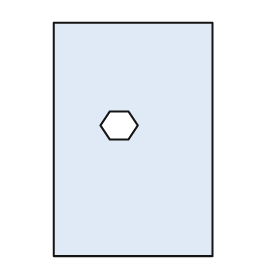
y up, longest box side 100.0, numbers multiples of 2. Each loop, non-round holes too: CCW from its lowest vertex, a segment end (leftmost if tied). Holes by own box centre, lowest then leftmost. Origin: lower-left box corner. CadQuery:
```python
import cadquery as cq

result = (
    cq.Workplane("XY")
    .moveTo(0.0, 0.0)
    .lineTo(68.0, 0.0)
    .lineTo(68.0, 100.0)
    .lineTo(0.0, 100.0)
    .close()
    .moveTo(24.0, 50.0)
    .lineTo(32.0, 50.0)
    .lineTo(36.0, 56.0)
    .lineTo(32.0, 62.0)
    .lineTo(24.0, 62.0)
    .lineTo(20.0, 56.0)
    .close()
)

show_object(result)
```